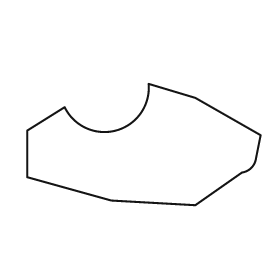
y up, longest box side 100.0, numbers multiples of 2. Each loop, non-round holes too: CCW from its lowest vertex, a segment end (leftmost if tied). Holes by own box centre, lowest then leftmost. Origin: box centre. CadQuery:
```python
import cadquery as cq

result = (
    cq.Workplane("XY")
    .moveTo(22.0, -26.0)
    .lineTo(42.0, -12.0)
    .threePointArc((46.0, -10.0), (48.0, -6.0))
    .lineTo(50.0, 4.0)
    .lineTo(22.0, 20.0)
    .lineTo(2.0, 26.0)
    .threePointArc((-12.0, 6.0), (-34.0, 16.0))
    .lineTo(-50.0, 6.0)
    .lineTo(-50.0, -14.0)
    .lineTo(-14.0, -24.0)
    .close()
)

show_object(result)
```